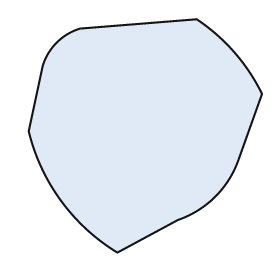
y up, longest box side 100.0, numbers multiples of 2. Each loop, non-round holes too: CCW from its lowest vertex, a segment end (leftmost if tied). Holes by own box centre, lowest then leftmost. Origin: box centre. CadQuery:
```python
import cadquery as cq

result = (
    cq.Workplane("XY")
    .moveTo(-12.0, -50.0)
    .lineTo(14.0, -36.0)
    .threePointArc((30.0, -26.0), (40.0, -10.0))
    .lineTo(50.0, 18.0)
    .threePointArc((38.0, 36.0), (22.0, 50.0))
    .lineTo(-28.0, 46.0)
    .threePointArc((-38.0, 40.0), (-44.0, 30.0))
    .lineTo(-50.0, 2.0)
    .threePointArc((-36.0, -28.0), (-12.0, -50.0))
    .close()
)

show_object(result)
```